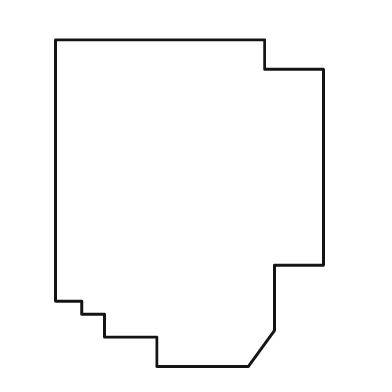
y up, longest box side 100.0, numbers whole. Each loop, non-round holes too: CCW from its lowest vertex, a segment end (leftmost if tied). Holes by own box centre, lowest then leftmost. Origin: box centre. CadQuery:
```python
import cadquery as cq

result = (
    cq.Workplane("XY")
    .moveTo(-10.0, -50.0)
    .lineTo(18.0, -50.0)
    .lineTo(26.0, -39.0)
    .lineTo(26.0, -19.0)
    .lineTo(41.0, -19.0)
    .lineTo(41.0, 41.0)
    .lineTo(23.0, 41.0)
    .lineTo(23.0, 50.0)
    .lineTo(-41.0, 50.0)
    .lineTo(-41.0, -30.0)
    .lineTo(-33.0, -30.0)
    .lineTo(-33.0, -34.0)
    .lineTo(-26.0, -34.0)
    .lineTo(-26.0, -41.0)
    .lineTo(-10.0, -41.0)
    .close()
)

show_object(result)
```